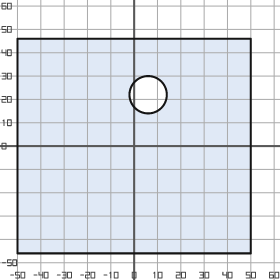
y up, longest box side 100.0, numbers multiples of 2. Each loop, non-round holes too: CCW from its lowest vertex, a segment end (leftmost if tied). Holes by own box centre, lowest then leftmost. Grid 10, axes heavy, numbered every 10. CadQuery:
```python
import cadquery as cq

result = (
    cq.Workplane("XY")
    .moveTo(-50.0, -46.0)
    .lineTo(50.0, -46.0)
    .lineTo(50.0, 46.0)
    .lineTo(-50.0, 46.0)
    .close()
    .moveTo(6.0, 22.0)
    .circle(8.0)
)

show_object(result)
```